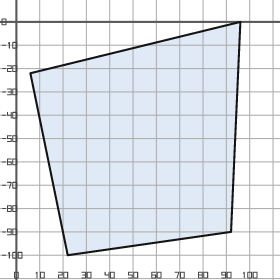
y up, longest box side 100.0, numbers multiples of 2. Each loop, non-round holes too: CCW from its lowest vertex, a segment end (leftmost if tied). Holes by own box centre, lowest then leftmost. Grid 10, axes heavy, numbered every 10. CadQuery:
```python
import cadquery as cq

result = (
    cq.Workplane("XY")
    .moveTo(22.0, -100.0)
    .lineTo(92.0, -90.0)
    .lineTo(96.0, 0.0)
    .lineTo(6.0, -22.0)
    .close()
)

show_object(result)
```